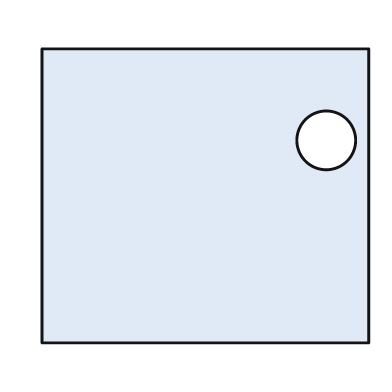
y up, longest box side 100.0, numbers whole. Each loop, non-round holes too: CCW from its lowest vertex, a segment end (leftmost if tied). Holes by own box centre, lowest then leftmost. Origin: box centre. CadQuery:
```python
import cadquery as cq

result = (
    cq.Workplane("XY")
    .moveTo(-50.0, -45.0)
    .lineTo(50.0, -45.0)
    .lineTo(50.0, 45.0)
    .lineTo(-50.0, 45.0)
    .close()
    .moveTo(37.0, 17.0)
    .circle(9.0)
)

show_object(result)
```